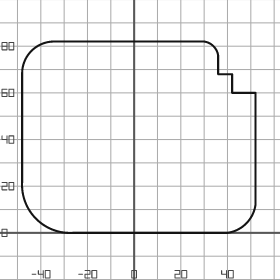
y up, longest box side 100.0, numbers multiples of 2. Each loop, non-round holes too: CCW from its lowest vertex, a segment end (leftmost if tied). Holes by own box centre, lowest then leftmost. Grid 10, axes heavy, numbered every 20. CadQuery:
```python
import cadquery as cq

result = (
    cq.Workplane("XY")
    .moveTo(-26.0, 0.0)
    .lineTo(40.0, 0.0)
    .threePointArc((48.0, 4.0), (52.0, 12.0))
    .lineTo(52.0, 60.0)
    .lineTo(42.0, 60.0)
    .lineTo(42.0, 68.0)
    .lineTo(36.0, 68.0)
    .lineTo(36.0, 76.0)
    .threePointArc((34.0, 80.0), (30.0, 82.0))
    .lineTo(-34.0, 82.0)
    .threePointArc((-44.0, 78.0), (-48.0, 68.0))
    .lineTo(-48.0, 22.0)
    .threePointArc((-42.0, 6.0), (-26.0, 0.0))
    .close()
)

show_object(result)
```